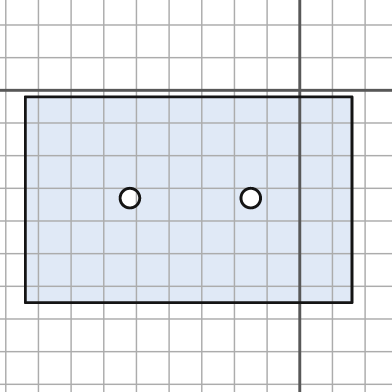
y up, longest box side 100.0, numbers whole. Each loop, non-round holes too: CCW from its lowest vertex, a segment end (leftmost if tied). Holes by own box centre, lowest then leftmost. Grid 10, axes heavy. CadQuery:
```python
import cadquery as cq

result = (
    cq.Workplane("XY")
    .moveTo(-84.0, -65.0)
    .lineTo(16.0, -65.0)
    .lineTo(16.0, -2.0)
    .lineTo(-84.0, -2.0)
    .close()
    .moveTo(-52.0, -33.0)
    .circle(3.0)
    .moveTo(-15.0, -33.0)
    .circle(3.0)
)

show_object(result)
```